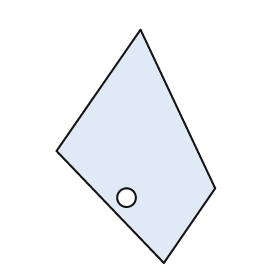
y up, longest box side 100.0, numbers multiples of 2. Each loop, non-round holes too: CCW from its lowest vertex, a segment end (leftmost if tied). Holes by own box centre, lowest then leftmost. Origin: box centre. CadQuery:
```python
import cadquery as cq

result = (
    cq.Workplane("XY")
    .moveTo(12.0, -50.0)
    .lineTo(34.0, -18.0)
    .lineTo(2.0, 50.0)
    .lineTo(-34.0, -2.0)
    .close()
    .moveTo(-4.0, -22.0)
    .circle(4.0)
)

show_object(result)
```